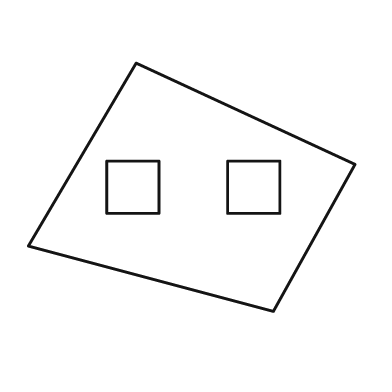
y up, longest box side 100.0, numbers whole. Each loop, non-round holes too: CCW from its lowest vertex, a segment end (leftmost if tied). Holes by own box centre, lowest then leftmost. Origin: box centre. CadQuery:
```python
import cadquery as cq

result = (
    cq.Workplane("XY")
    .moveTo(25.0, -38.0)
    .lineTo(50.0, 7.0)
    .lineTo(-17.0, 38.0)
    .lineTo(-50.0, -18.0)
    .close()
    .moveTo(-26.0, -8.0)
    .lineTo(-10.0, -8.0)
    .lineTo(-10.0, 8.0)
    .lineTo(-26.0, 8.0)
    .close()
    .moveTo(11.0, -8.0)
    .lineTo(27.0, -8.0)
    .lineTo(27.0, 8.0)
    .lineTo(11.0, 8.0)
    .close()
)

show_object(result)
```